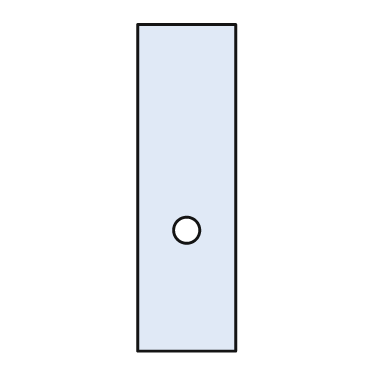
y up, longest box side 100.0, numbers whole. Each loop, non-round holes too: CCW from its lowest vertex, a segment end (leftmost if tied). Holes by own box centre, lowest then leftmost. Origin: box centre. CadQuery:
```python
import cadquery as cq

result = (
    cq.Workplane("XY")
    .moveTo(-15.0, -50.0)
    .lineTo(15.0, -50.0)
    .lineTo(15.0, 50.0)
    .lineTo(-15.0, 50.0)
    .close()
    .moveTo(0.0, -13.0)
    .circle(4.0)
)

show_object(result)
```